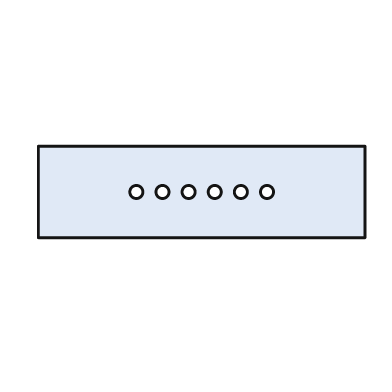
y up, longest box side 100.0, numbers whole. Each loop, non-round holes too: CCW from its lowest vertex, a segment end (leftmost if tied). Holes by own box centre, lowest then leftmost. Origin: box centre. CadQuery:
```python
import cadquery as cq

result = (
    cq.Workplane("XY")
    .moveTo(-50.0, -14.0)
    .lineTo(50.0, -14.0)
    .lineTo(50.0, 14.0)
    .lineTo(-50.0, 14.0)
    .close()
    .moveTo(-20.0, 0.0)
    .circle(2.0)
    .moveTo(-12.0, 0.0)
    .circle(2.0)
    .moveTo(-4.0, 0.0)
    .circle(2.0)
    .moveTo(4.0, 0.0)
    .circle(2.0)
    .moveTo(12.0, 0.0)
    .circle(2.0)
    .moveTo(20.0, 0.0)
    .circle(2.0)
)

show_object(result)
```